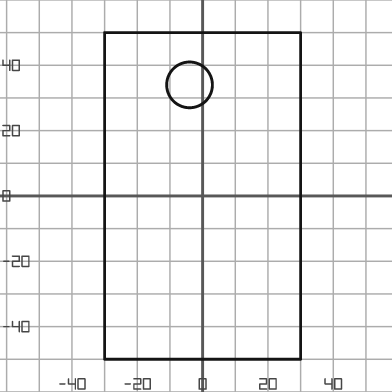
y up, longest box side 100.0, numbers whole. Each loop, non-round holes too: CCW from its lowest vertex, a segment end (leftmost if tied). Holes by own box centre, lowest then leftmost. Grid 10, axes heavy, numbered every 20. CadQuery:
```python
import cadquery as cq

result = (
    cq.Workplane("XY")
    .moveTo(-30.0, -50.0)
    .lineTo(30.0, -50.0)
    .lineTo(30.0, 50.0)
    .lineTo(-30.0, 50.0)
    .close()
    .moveTo(-4.0, 34.0)
    .circle(7.0)
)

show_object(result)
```